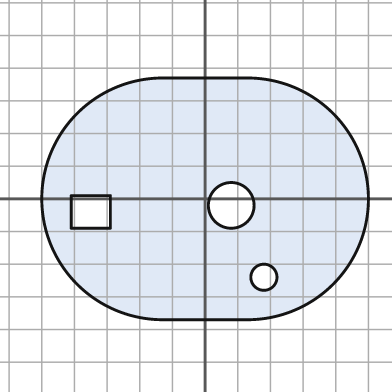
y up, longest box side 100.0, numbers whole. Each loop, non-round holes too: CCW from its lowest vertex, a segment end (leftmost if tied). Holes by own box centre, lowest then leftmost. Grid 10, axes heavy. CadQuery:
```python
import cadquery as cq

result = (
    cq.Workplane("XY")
    .moveTo(-13.0, -37.0)
    .lineTo(13.0, -37.0)
    .threePointArc((50.0, 0.0), (13.0, 37.0))
    .lineTo(-13.0, 37.0)
    .threePointArc((-50.0, 0.0), (-13.0, -37.0))
    .close()
    .moveTo(18.0, -24.0)
    .circle(4.0)
    .moveTo(-41.0, -9.0)
    .lineTo(-29.0, -9.0)
    .lineTo(-29.0, 1.0)
    .lineTo(-41.0, 1.0)
    .close()
    .moveTo(8.0, -2.0)
    .circle(7.0)
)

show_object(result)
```